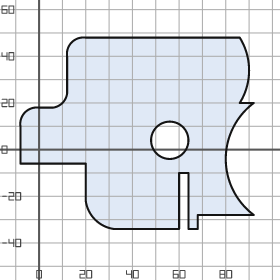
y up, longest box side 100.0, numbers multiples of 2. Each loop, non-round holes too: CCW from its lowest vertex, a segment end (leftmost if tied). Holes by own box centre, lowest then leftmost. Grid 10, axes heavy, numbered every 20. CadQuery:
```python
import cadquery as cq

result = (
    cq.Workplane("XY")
    .moveTo(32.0, -34.0)
    .lineTo(60.0, -34.0)
    .lineTo(60.0, -10.0)
    .lineTo(64.0, -10.0)
    .lineTo(64.0, -34.0)
    .lineTo(68.0, -34.0)
    .lineTo(68.0, -28.0)
    .lineTo(92.0, -28.0)
    .threePointArc((80.0, -4.0), (92.0, 20.0))
    .lineTo(86.0, 20.0)
    .threePointArc((90.0, 34.0), (86.0, 48.0))
    .lineTo(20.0, 48.0)
    .threePointArc((14.0, 46.0), (12.0, 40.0))
    .lineTo(12.0, 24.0)
    .threePointArc((10.0, 20.0), (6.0, 18.0))
    .lineTo(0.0, 18.0)
    .threePointArc((-6.0, 16.0), (-8.0, 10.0))
    .lineTo(-8.0, -6.0)
    .lineTo(20.0, -6.0)
    .lineTo(20.0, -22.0)
    .threePointArc((24.0, -30.0), (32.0, -34.0))
    .close()
    .moveTo(56.0, 4.0)
    .circle(8.0)
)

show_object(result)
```